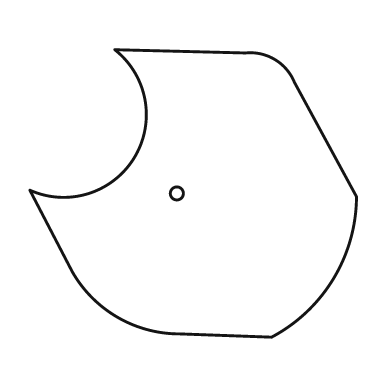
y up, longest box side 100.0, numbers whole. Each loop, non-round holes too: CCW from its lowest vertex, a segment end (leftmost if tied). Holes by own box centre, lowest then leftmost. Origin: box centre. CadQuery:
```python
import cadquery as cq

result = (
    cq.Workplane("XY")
    .moveTo(24.0, -44.0)
    .threePointArc((43.0, -26.0), (50.0, -1.0))
    .lineTo(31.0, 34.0)
    .threePointArc((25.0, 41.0), (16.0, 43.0))
    .lineTo(-24.0, 44.0)
    .threePointArc((-18.0, 11.0), (-50.0, 1.0))
    .lineTo(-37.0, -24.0)
    .threePointArc((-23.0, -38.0), (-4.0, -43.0))
    .close()
    .moveTo(-5.0, 0.0)
    .circle(2.0)
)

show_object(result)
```